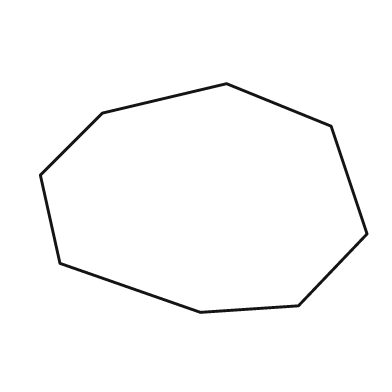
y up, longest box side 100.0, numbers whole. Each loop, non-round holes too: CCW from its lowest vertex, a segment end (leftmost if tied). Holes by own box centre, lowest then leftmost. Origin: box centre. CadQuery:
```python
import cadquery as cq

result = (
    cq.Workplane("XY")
    .moveTo(-1.0, -35.0)
    .lineTo(29.0, -33.0)
    .lineTo(50.0, -11.0)
    .lineTo(39.0, 22.0)
    .lineTo(7.0, 35.0)
    .lineTo(-31.0, 26.0)
    .lineTo(-50.0, 7.0)
    .lineTo(-44.0, -20.0)
    .close()
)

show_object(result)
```